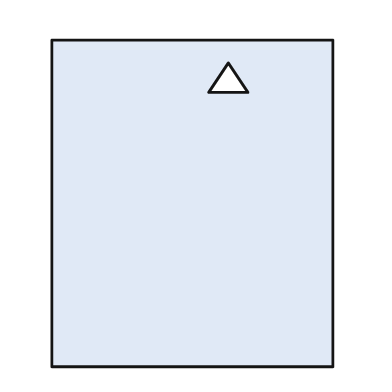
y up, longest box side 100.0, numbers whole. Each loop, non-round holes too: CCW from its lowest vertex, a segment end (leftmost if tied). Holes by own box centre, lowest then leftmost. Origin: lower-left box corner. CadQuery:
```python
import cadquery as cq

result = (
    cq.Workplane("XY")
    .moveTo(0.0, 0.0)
    .lineTo(86.0, 0.0)
    .lineTo(86.0, 100.0)
    .lineTo(0.0, 100.0)
    .close()
    .moveTo(48.0, 84.0)
    .lineTo(60.0, 84.0)
    .lineTo(54.0, 93.0)
    .close()
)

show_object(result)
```